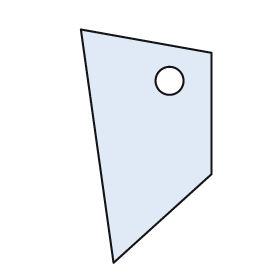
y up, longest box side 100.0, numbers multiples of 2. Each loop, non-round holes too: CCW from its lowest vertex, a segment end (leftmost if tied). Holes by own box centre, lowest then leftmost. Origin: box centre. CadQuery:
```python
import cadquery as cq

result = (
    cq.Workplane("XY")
    .moveTo(-14.0, -50.0)
    .lineTo(28.0, -12.0)
    .lineTo(28.0, 40.0)
    .lineTo(-28.0, 50.0)
    .close()
    .moveTo(10.0, 28.0)
    .circle(6.0)
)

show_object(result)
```